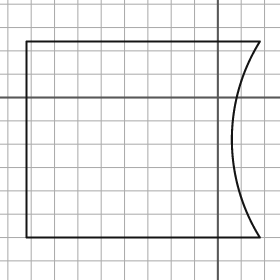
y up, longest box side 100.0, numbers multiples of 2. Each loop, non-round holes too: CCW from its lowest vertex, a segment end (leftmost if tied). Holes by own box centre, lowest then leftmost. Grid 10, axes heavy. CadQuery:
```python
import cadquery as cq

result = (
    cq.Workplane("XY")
    .moveTo(-82.0, -60.0)
    .lineTo(18.0, -60.0)
    .threePointArc((6.0, -18.0), (18.0, 24.0))
    .lineTo(-82.0, 24.0)
    .close()
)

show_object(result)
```